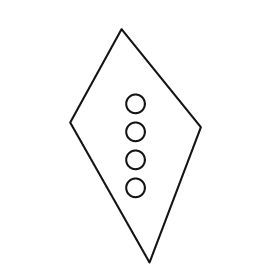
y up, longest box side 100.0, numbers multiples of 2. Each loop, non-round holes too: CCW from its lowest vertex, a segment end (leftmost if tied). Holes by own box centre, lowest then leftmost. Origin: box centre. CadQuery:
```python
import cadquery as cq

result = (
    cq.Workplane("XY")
    .moveTo(6.0, -50.0)
    .lineTo(28.0, 8.0)
    .lineTo(-6.0, 50.0)
    .lineTo(-28.0, 10.0)
    .close()
    .moveTo(0.0, -18.0)
    .circle(4.0)
    .moveTo(0.0, -6.0)
    .circle(4.0)
    .moveTo(0.0, 6.0)
    .circle(4.0)
    .moveTo(0.0, 18.0)
    .circle(4.0)
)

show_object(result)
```